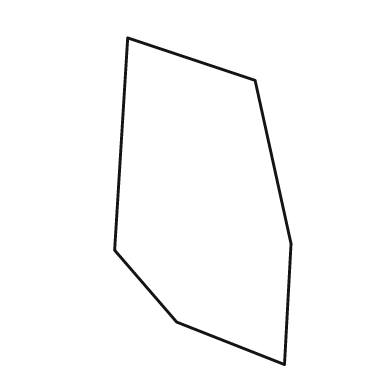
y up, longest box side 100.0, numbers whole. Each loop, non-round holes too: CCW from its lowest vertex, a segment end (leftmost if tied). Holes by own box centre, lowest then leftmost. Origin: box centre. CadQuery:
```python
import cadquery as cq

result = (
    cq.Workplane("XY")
    .moveTo(25.0, -50.0)
    .lineTo(27.0, -13.0)
    .lineTo(16.0, 37.0)
    .lineTo(-23.0, 50.0)
    .lineTo(-27.0, -15.0)
    .lineTo(-8.0, -37.0)
    .close()
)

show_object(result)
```